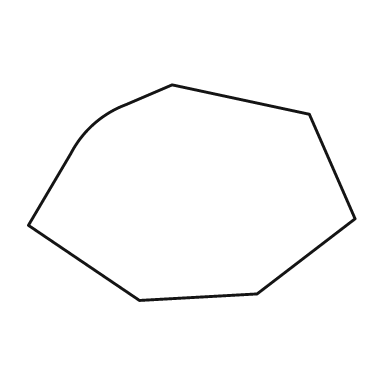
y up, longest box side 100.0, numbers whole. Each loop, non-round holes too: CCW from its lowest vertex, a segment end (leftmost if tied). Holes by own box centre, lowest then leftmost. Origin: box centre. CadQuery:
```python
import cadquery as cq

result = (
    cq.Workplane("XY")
    .moveTo(-16.0, -33.0)
    .lineTo(20.0, -31.0)
    .lineTo(50.0, -8.0)
    .lineTo(36.0, 24.0)
    .lineTo(-6.0, 33.0)
    .lineTo(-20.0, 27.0)
    .threePointArc((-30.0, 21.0), (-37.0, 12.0))
    .lineTo(-50.0, -10.0)
    .close()
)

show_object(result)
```